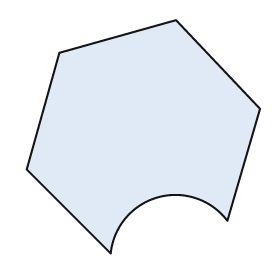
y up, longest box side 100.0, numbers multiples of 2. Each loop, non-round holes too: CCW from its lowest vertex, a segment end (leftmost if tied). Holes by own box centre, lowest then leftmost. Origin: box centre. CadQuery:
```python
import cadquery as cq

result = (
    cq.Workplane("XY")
    .moveTo(-14.0, -50.0)
    .threePointArc((6.0, -26.0), (36.0, -36.0))
    .lineTo(50.0, 12.0)
    .lineTo(14.0, 50.0)
    .lineTo(-36.0, 36.0)
    .lineTo(-50.0, -14.0)
    .close()
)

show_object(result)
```